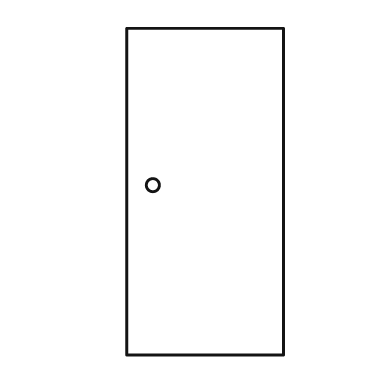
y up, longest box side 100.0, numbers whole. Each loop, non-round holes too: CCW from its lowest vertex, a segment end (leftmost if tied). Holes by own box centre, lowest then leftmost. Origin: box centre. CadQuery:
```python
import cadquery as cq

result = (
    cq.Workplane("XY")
    .moveTo(-24.0, -50.0)
    .lineTo(24.0, -50.0)
    .lineTo(24.0, 50.0)
    .lineTo(-24.0, 50.0)
    .close()
    .moveTo(-16.0, 2.0)
    .circle(2.0)
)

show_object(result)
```